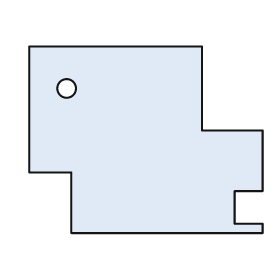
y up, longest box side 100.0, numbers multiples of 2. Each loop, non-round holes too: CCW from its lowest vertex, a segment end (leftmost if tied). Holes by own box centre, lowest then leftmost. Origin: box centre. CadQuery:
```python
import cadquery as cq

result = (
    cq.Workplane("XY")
    .moveTo(-32.0, -40.0)
    .lineTo(50.0, -40.0)
    .lineTo(50.0, -36.0)
    .lineTo(38.0, -36.0)
    .lineTo(38.0, -22.0)
    .lineTo(50.0, -22.0)
    .lineTo(50.0, 4.0)
    .lineTo(24.0, 4.0)
    .lineTo(24.0, 40.0)
    .lineTo(-50.0, 40.0)
    .lineTo(-50.0, -14.0)
    .lineTo(-32.0, -14.0)
    .close()
    .moveTo(-34.0, 22.0)
    .circle(4.0)
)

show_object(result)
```